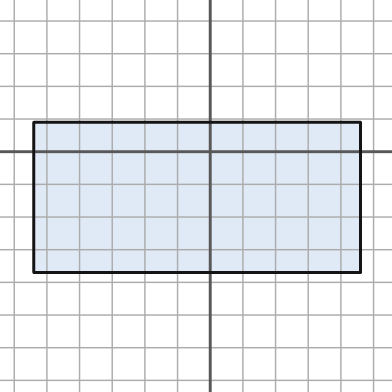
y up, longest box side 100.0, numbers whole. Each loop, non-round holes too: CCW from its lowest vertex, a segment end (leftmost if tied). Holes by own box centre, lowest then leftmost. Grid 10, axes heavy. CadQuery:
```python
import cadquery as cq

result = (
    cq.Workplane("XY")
    .moveTo(-54.0, -37.0)
    .lineTo(46.0, -37.0)
    .lineTo(46.0, 9.0)
    .lineTo(-54.0, 9.0)
    .close()
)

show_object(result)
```